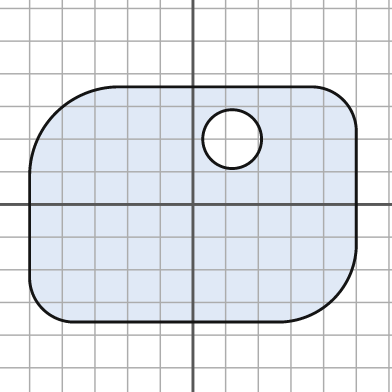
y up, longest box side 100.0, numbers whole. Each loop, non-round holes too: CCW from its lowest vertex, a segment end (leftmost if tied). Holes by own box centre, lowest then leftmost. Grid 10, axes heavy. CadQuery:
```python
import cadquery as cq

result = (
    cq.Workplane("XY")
    .moveTo(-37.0, -36.0)
    .lineTo(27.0, -36.0)
    .threePointArc((43.0, -29.0), (50.0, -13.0))
    .lineTo(50.0, 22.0)
    .threePointArc((46.0, 32.0), (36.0, 36.0))
    .lineTo(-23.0, 36.0)
    .threePointArc((-42.0, 28.0), (-50.0, 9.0))
    .lineTo(-50.0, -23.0)
    .threePointArc((-46.0, -32.0), (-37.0, -36.0))
    .close()
    .moveTo(12.0, 20.0)
    .circle(9.0)
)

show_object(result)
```